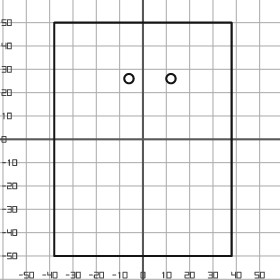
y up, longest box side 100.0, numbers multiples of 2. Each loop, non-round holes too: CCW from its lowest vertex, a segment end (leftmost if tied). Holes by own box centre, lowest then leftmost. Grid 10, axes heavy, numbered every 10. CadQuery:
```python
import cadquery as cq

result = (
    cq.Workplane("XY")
    .moveTo(-38.0, -50.0)
    .lineTo(38.0, -50.0)
    .lineTo(38.0, 50.0)
    .lineTo(-38.0, 50.0)
    .close()
    .moveTo(-6.0, 26.0)
    .circle(2.0)
    .moveTo(12.0, 26.0)
    .circle(2.0)
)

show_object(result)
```